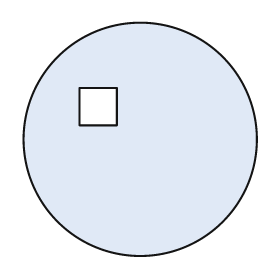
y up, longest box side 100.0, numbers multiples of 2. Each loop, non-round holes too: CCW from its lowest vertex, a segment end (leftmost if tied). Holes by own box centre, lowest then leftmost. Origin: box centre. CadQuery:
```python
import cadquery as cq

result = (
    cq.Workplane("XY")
    .moveTo(0.0, 0.0)
    .circle(50.0)
    .moveTo(-26.0, 6.0)
    .lineTo(-10.0, 6.0)
    .lineTo(-10.0, 22.0)
    .lineTo(-26.0, 22.0)
    .close()
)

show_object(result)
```